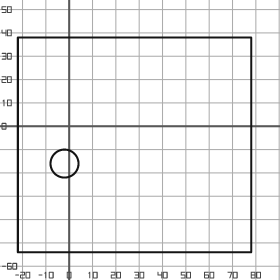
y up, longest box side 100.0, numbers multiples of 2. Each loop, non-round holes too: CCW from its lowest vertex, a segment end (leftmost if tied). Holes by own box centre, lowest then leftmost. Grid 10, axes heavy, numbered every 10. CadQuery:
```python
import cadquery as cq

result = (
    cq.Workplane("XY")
    .moveTo(-22.0, -54.0)
    .lineTo(78.0, -54.0)
    .lineTo(78.0, 38.0)
    .lineTo(-22.0, 38.0)
    .close()
    .moveTo(-2.0, -16.0)
    .circle(6.0)
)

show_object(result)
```